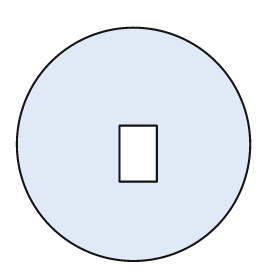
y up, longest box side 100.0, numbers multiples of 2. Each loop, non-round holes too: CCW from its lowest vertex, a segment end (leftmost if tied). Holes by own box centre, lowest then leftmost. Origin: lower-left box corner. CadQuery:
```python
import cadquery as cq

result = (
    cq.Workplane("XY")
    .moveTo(50.0, 50.0)
    .circle(50.0)
    .moveTo(44.0, 34.0)
    .lineTo(60.0, 34.0)
    .lineTo(60.0, 58.0)
    .lineTo(44.0, 58.0)
    .close()
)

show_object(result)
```